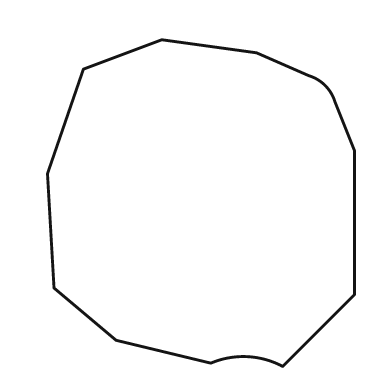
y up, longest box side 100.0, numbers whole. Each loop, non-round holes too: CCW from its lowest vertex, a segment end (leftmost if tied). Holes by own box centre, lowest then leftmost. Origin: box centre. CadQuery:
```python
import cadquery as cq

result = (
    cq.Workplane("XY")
    .moveTo(25.0, -50.0)
    .lineTo(47.0, -28.0)
    .lineTo(47.0, 16.0)
    .lineTo(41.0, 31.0)
    .threePointArc((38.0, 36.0), (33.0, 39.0))
    .lineTo(17.0, 46.0)
    .lineTo(-12.0, 50.0)
    .lineTo(-36.0, 41.0)
    .lineTo(-47.0, 9.0)
    .lineTo(-45.0, -26.0)
    .lineTo(-26.0, -42.0)
    .lineTo(3.0, -49.0)
    .threePointArc((14.0, -47.0), (25.0, -50.0))
    .close()
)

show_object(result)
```